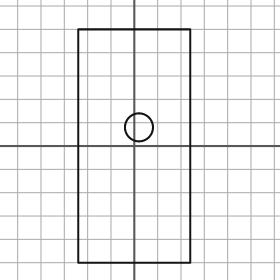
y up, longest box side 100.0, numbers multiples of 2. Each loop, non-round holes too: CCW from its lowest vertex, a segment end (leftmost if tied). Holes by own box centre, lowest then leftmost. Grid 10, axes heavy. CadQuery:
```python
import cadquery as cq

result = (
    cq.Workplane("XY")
    .moveTo(-24.0, -50.0)
    .lineTo(24.0, -50.0)
    .lineTo(24.0, 50.0)
    .lineTo(-24.0, 50.0)
    .close()
    .moveTo(2.0, 8.0)
    .circle(6.0)
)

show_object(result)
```